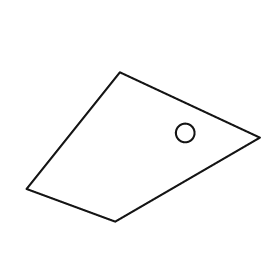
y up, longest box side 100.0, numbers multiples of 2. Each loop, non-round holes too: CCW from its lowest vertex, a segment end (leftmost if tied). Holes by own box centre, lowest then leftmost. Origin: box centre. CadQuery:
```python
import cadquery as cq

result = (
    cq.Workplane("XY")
    .moveTo(-12.0, -32.0)
    .lineTo(50.0, 4.0)
    .lineTo(-10.0, 32.0)
    .lineTo(-50.0, -18.0)
    .close()
    .moveTo(18.0, 6.0)
    .circle(4.0)
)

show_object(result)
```